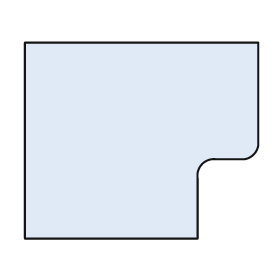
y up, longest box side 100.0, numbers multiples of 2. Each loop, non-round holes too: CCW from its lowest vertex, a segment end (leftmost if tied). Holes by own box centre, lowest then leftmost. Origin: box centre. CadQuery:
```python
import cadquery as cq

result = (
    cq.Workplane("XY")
    .moveTo(-50.0, -42.0)
    .lineTo(24.0, -42.0)
    .lineTo(24.0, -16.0)
    .threePointArc((26.0, -10.0), (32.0, -8.0))
    .lineTo(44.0, -8.0)
    .threePointArc((48.0, -6.0), (50.0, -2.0))
    .lineTo(50.0, 42.0)
    .lineTo(-50.0, 42.0)
    .close()
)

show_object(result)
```